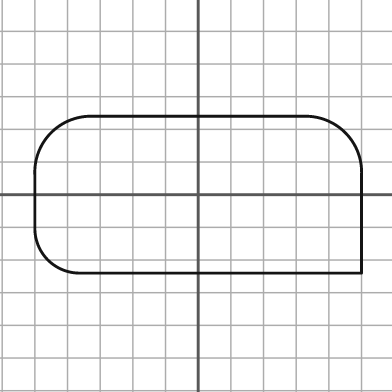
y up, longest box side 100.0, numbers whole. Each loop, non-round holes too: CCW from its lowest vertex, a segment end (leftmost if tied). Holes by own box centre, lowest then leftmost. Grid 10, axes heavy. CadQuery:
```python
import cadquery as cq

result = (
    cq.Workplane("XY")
    .moveTo(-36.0, -24.0)
    .lineTo(50.0, -24.0)
    .lineTo(50.0, 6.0)
    .threePointArc((45.0, 19.0), (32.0, 24.0))
    .lineTo(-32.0, 24.0)
    .threePointArc((-45.0, 19.0), (-50.0, 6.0))
    .lineTo(-50.0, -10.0)
    .threePointArc((-46.0, -20.0), (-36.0, -24.0))
    .close()
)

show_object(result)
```